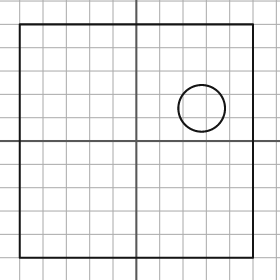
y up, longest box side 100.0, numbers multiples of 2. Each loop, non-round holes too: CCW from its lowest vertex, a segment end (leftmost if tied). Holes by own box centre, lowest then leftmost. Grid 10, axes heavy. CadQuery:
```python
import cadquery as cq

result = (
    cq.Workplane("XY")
    .moveTo(-50.0, -50.0)
    .lineTo(50.0, -50.0)
    .lineTo(50.0, 50.0)
    .lineTo(-50.0, 50.0)
    .close()
    .moveTo(28.0, 14.0)
    .circle(10.0)
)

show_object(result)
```